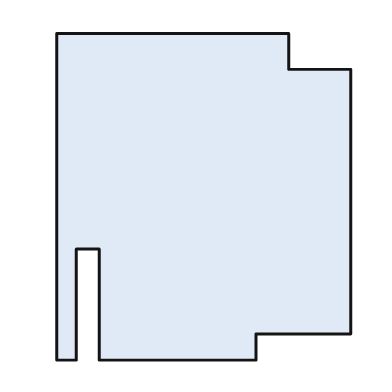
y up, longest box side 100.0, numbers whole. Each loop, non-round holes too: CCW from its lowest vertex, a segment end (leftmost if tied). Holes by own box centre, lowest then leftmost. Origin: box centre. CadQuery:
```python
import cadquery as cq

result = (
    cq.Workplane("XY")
    .moveTo(-45.0, -50.0)
    .lineTo(-39.0, -50.0)
    .lineTo(-39.0, -16.0)
    .lineTo(-32.0, -16.0)
    .lineTo(-32.0, -50.0)
    .lineTo(16.0, -50.0)
    .lineTo(16.0, -42.0)
    .lineTo(45.0, -42.0)
    .lineTo(45.0, 39.0)
    .lineTo(26.0, 39.0)
    .lineTo(26.0, 50.0)
    .lineTo(-45.0, 50.0)
    .close()
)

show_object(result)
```